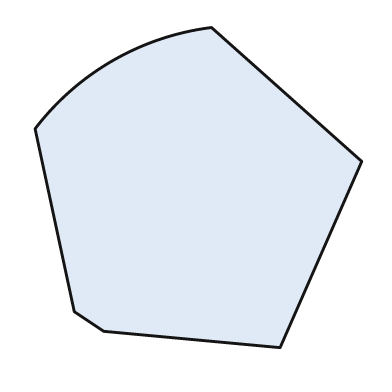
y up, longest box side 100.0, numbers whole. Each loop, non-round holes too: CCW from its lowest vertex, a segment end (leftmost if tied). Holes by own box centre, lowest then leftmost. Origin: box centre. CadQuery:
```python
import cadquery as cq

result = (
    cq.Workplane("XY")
    .moveTo(25.0, -49.0)
    .lineTo(50.0, 8.0)
    .lineTo(4.0, 49.0)
    .threePointArc((-26.0, 39.0), (-50.0, 18.0))
    .lineTo(-38.0, -38.0)
    .lineTo(-29.0, -44.0)
    .close()
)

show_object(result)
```